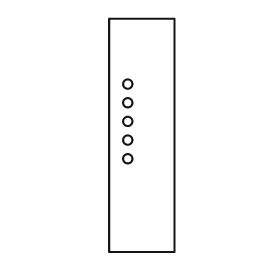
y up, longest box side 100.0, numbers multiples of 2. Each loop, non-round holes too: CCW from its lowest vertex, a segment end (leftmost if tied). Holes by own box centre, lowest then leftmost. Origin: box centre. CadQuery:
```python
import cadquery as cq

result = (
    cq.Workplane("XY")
    .moveTo(-14.0, -50.0)
    .lineTo(14.0, -50.0)
    .lineTo(14.0, 50.0)
    .lineTo(-14.0, 50.0)
    .close()
    .moveTo(-6.0, -10.0)
    .circle(2.0)
    .moveTo(-6.0, -2.0)
    .circle(2.0)
    .moveTo(-6.0, 6.0)
    .circle(2.0)
    .moveTo(-6.0, 14.0)
    .circle(2.0)
    .moveTo(-6.0, 22.0)
    .circle(2.0)
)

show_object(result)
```